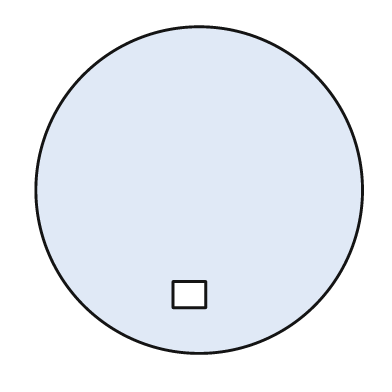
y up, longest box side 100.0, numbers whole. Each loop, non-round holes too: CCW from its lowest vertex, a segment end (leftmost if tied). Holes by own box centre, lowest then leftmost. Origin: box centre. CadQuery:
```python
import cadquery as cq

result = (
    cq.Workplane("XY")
    .moveTo(0.0, 0.0)
    .circle(50.0)
    .moveTo(-8.0, -36.0)
    .lineTo(2.0, -36.0)
    .lineTo(2.0, -28.0)
    .lineTo(-8.0, -28.0)
    .close()
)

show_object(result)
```